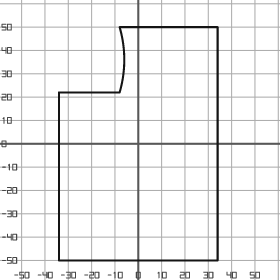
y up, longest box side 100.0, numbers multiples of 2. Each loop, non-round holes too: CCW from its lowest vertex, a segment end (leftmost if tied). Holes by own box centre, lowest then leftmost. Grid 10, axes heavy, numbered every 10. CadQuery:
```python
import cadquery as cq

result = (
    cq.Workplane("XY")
    .moveTo(-34.0, -50.0)
    .lineTo(34.0, -50.0)
    .lineTo(34.0, 50.0)
    .lineTo(-8.0, 50.0)
    .threePointArc((-6.0, 36.0), (-8.0, 22.0))
    .lineTo(-34.0, 22.0)
    .close()
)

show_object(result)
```